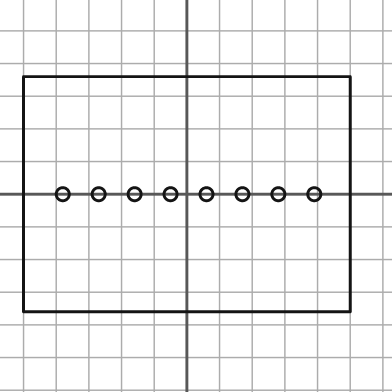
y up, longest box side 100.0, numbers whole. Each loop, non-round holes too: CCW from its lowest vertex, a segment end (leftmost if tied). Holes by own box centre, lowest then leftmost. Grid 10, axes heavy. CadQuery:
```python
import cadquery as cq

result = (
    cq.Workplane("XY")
    .moveTo(-50.0, -36.0)
    .lineTo(50.0, -36.0)
    .lineTo(50.0, 36.0)
    .lineTo(-50.0, 36.0)
    .close()
    .moveTo(-38.0, 0.0)
    .circle(2.0)
    .moveTo(-27.0, 0.0)
    .circle(2.0)
    .moveTo(-16.0, 0.0)
    .circle(2.0)
    .moveTo(-5.0, 0.0)
    .circle(2.0)
    .moveTo(6.0, 0.0)
    .circle(2.0)
    .moveTo(17.0, 0.0)
    .circle(2.0)
    .moveTo(28.0, 0.0)
    .circle(2.0)
    .moveTo(39.0, 0.0)
    .circle(2.0)
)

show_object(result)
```